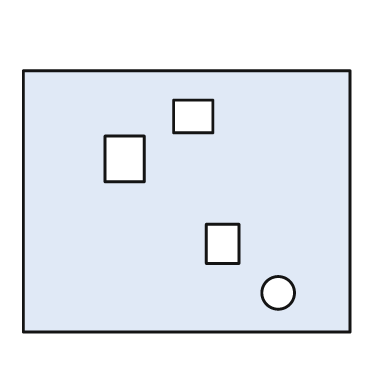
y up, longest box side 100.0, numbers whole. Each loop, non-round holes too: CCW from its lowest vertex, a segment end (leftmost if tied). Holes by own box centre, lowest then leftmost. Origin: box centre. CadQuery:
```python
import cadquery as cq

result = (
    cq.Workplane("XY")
    .moveTo(-50.0, -40.0)
    .lineTo(50.0, -40.0)
    .lineTo(50.0, 40.0)
    .lineTo(-50.0, 40.0)
    .close()
    .moveTo(28.0, -28.0)
    .circle(5.0)
    .moveTo(6.0, -19.0)
    .lineTo(16.0, -19.0)
    .lineTo(16.0, -7.0)
    .lineTo(6.0, -7.0)
    .close()
    .moveTo(-25.0, 6.0)
    .lineTo(-13.0, 6.0)
    .lineTo(-13.0, 20.0)
    .lineTo(-25.0, 20.0)
    .close()
    .moveTo(-4.0, 21.0)
    .lineTo(8.0, 21.0)
    .lineTo(8.0, 31.0)
    .lineTo(-4.0, 31.0)
    .close()
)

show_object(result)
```